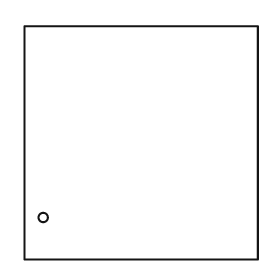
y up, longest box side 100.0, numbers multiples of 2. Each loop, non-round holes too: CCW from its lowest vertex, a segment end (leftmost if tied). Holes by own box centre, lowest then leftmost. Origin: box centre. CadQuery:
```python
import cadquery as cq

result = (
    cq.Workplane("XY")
    .moveTo(-50.0, -50.0)
    .lineTo(50.0, -50.0)
    .lineTo(50.0, 50.0)
    .lineTo(-50.0, 50.0)
    .close()
    .moveTo(-42.0, -32.0)
    .circle(2.0)
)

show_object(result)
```